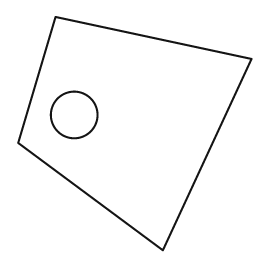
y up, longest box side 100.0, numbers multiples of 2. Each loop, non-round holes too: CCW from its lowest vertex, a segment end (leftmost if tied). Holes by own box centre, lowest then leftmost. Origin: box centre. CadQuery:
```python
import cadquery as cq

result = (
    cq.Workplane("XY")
    .moveTo(12.0, -50.0)
    .lineTo(50.0, 32.0)
    .lineTo(-34.0, 50.0)
    .lineTo(-50.0, -4.0)
    .close()
    .moveTo(-26.0, 8.0)
    .circle(10.0)
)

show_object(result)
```